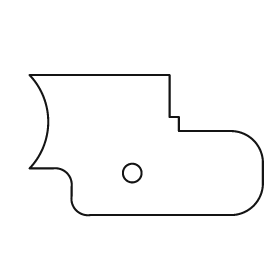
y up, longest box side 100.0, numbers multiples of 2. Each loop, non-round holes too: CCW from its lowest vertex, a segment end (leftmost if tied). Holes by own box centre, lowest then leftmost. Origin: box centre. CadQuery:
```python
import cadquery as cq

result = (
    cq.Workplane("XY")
    .moveTo(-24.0, -30.0)
    .lineTo(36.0, -30.0)
    .threePointArc((46.0, -26.0), (50.0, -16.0))
    .lineTo(50.0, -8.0)
    .threePointArc((46.0, 2.0), (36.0, 6.0))
    .lineTo(14.0, 6.0)
    .lineTo(14.0, 12.0)
    .lineTo(10.0, 12.0)
    .lineTo(10.0, 30.0)
    .lineTo(-50.0, 30.0)
    .threePointArc((-42.0, 10.0), (-50.0, -10.0))
    .lineTo(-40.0, -10.0)
    .threePointArc((-34.0, -12.0), (-32.0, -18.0))
    .lineTo(-32.0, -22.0)
    .threePointArc((-30.0, -28.0), (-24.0, -30.0))
    .close()
    .moveTo(-6.0, -12.0)
    .circle(4.0)
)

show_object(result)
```